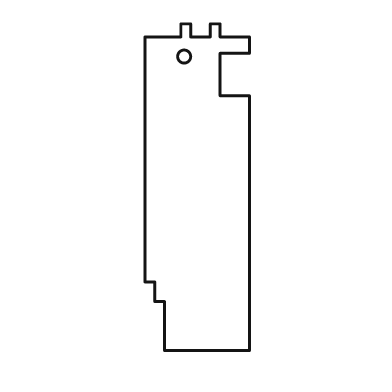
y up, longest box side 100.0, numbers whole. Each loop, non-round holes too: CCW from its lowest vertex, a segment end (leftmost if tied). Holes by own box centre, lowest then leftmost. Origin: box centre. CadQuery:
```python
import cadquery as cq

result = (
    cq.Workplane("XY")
    .moveTo(-10.0, -50.0)
    .lineTo(16.0, -50.0)
    .lineTo(16.0, 28.0)
    .lineTo(7.0, 28.0)
    .lineTo(7.0, 41.0)
    .lineTo(16.0, 41.0)
    .lineTo(16.0, 46.0)
    .lineTo(7.0, 46.0)
    .lineTo(7.0, 50.0)
    .lineTo(4.0, 50.0)
    .lineTo(4.0, 46.0)
    .lineTo(-2.0, 46.0)
    .lineTo(-2.0, 50.0)
    .lineTo(-5.0, 50.0)
    .lineTo(-5.0, 46.0)
    .lineTo(-16.0, 46.0)
    .lineTo(-16.0, -29.0)
    .lineTo(-13.0, -29.0)
    .lineTo(-13.0, -35.0)
    .lineTo(-10.0, -35.0)
    .close()
    .moveTo(-4.0, 40.0)
    .circle(2.0)
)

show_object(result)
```